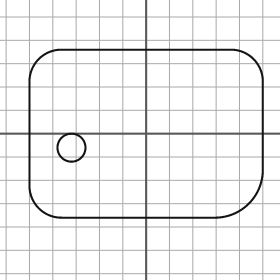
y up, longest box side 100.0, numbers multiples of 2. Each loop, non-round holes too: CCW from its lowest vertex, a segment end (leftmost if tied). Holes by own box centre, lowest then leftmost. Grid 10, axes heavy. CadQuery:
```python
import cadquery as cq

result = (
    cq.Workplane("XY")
    .moveTo(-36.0, -36.0)
    .lineTo(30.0, -36.0)
    .threePointArc((44.0, -30.0), (50.0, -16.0))
    .lineTo(50.0, 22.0)
    .threePointArc((46.0, 32.0), (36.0, 36.0))
    .lineTo(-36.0, 36.0)
    .threePointArc((-46.0, 32.0), (-50.0, 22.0))
    .lineTo(-50.0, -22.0)
    .threePointArc((-46.0, -32.0), (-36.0, -36.0))
    .close()
    .moveTo(-32.0, -6.0)
    .circle(6.0)
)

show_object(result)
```